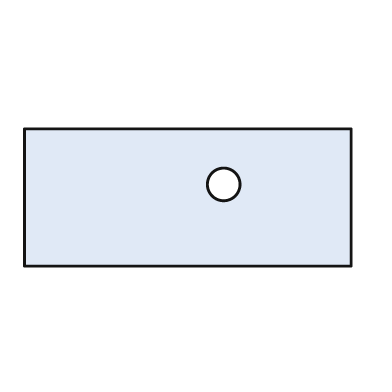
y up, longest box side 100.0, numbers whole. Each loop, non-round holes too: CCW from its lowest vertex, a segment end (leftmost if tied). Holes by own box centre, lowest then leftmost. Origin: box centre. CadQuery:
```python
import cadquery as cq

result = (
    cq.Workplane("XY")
    .moveTo(-50.0, -21.0)
    .lineTo(50.0, -21.0)
    .lineTo(50.0, 21.0)
    .lineTo(-50.0, 21.0)
    .close()
    .moveTo(11.0, 4.0)
    .circle(5.0)
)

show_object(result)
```